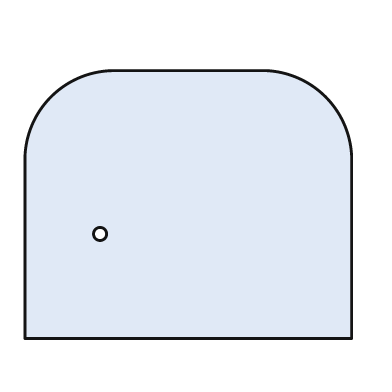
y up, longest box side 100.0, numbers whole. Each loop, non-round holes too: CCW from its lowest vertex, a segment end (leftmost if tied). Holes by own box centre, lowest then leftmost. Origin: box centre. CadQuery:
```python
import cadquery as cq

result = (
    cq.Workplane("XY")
    .moveTo(-50.0, -41.0)
    .lineTo(50.0, -41.0)
    .lineTo(50.0, 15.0)
    .threePointArc((42.0, 33.0), (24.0, 41.0))
    .lineTo(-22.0, 41.0)
    .threePointArc((-42.0, 33.0), (-50.0, 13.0))
    .close()
    .moveTo(-27.0, -9.0)
    .circle(2.0)
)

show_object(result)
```